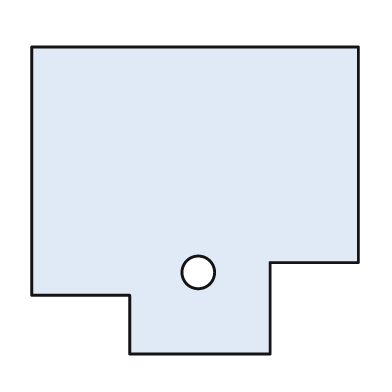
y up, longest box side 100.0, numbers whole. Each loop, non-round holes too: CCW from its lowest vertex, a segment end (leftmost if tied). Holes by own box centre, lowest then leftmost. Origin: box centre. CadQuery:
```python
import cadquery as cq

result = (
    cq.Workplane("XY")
    .moveTo(-20.0, -47.0)
    .lineTo(23.0, -47.0)
    .lineTo(23.0, -19.0)
    .lineTo(50.0, -19.0)
    .lineTo(50.0, 47.0)
    .lineTo(-50.0, 47.0)
    .lineTo(-50.0, -29.0)
    .lineTo(-20.0, -29.0)
    .close()
    .moveTo(1.0, -22.0)
    .circle(5.0)
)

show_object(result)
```